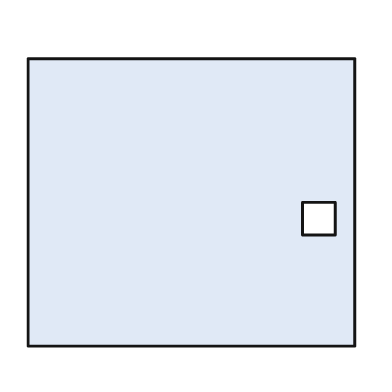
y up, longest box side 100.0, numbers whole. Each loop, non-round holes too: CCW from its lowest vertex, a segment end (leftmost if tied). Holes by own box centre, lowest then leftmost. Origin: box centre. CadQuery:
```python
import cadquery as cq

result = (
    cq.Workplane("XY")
    .moveTo(-50.0, -44.0)
    .lineTo(50.0, -44.0)
    .lineTo(50.0, 44.0)
    .lineTo(-50.0, 44.0)
    .close()
    .moveTo(34.0, -10.0)
    .lineTo(44.0, -10.0)
    .lineTo(44.0, 0.0)
    .lineTo(34.0, 0.0)
    .close()
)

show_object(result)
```